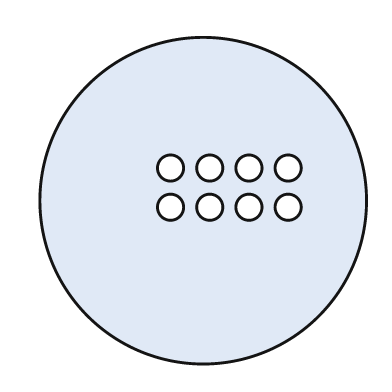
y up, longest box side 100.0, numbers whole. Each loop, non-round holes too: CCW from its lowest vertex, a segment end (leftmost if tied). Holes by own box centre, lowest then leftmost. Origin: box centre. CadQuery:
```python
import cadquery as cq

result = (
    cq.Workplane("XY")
    .moveTo(0.0, 0.0)
    .circle(50.0)
    .moveTo(-10.0, -2.0)
    .circle(4.0)
    .moveTo(2.0, -2.0)
    .circle(4.0)
    .moveTo(14.0, -2.0)
    .circle(4.0)
    .moveTo(26.0, -2.0)
    .circle(4.0)
    .moveTo(-10.0, 10.0)
    .circle(4.0)
    .moveTo(2.0, 10.0)
    .circle(4.0)
    .moveTo(14.0, 10.0)
    .circle(4.0)
    .moveTo(26.0, 10.0)
    .circle(4.0)
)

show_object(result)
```